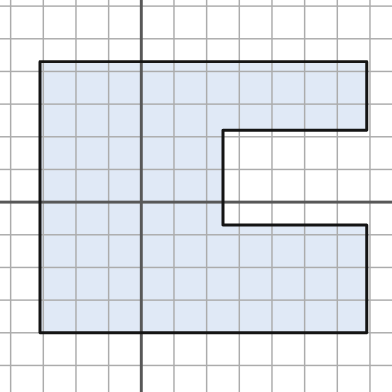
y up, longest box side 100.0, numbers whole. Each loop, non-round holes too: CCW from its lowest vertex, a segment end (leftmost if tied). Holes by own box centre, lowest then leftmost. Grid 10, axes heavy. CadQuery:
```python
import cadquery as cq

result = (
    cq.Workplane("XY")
    .moveTo(-31.0, -40.0)
    .lineTo(69.0, -40.0)
    .lineTo(69.0, -7.0)
    .lineTo(25.0, -7.0)
    .lineTo(25.0, 22.0)
    .lineTo(69.0, 22.0)
    .lineTo(69.0, 43.0)
    .lineTo(-31.0, 43.0)
    .close()
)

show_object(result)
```